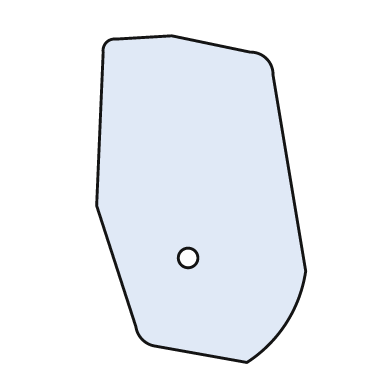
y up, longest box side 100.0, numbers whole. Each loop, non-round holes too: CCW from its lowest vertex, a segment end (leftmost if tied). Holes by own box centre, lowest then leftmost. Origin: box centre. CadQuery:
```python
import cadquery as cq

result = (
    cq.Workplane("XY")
    .moveTo(14.0, -50.0)
    .threePointArc((26.0, -38.0), (32.0, -22.0))
    .lineTo(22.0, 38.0)
    .threePointArc((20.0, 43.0), (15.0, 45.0))
    .lineTo(-9.0, 50.0)
    .lineTo(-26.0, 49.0)
    .threePointArc((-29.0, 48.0), (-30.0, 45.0))
    .lineTo(-32.0, -2.0)
    .lineTo(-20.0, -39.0)
    .threePointArc((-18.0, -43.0), (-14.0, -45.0))
    .close()
    .moveTo(-4.0, -18.0)
    .circle(3.0)
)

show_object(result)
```